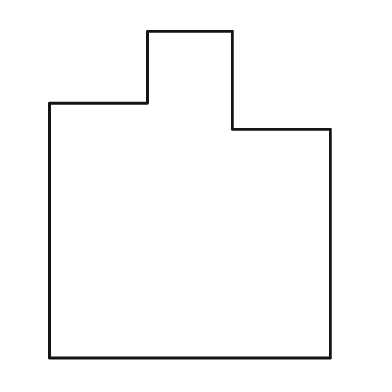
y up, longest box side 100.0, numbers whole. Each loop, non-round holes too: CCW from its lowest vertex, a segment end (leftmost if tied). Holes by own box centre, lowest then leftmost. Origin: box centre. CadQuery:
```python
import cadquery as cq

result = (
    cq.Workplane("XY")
    .moveTo(-43.0, -50.0)
    .lineTo(43.0, -50.0)
    .lineTo(43.0, 20.0)
    .lineTo(13.0, 20.0)
    .lineTo(13.0, 50.0)
    .lineTo(-13.0, 50.0)
    .lineTo(-13.0, 28.0)
    .lineTo(-43.0, 28.0)
    .close()
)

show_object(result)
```